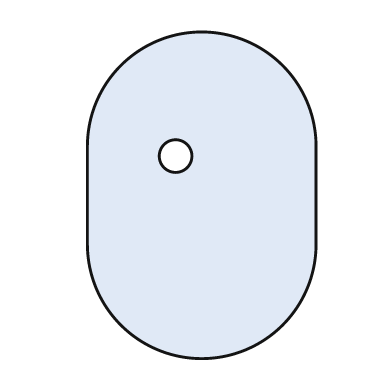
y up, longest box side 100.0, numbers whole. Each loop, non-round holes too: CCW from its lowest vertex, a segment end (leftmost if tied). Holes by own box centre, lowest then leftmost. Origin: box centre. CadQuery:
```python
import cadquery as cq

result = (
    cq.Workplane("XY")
    .moveTo(-35.0, -15.0)
    .threePointArc((0.0, -50.0), (35.0, -15.0))
    .lineTo(35.0, 15.0)
    .threePointArc((0.0, 50.0), (-35.0, 15.0))
    .close()
    .moveTo(-8.0, 12.0)
    .circle(5.0)
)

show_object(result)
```